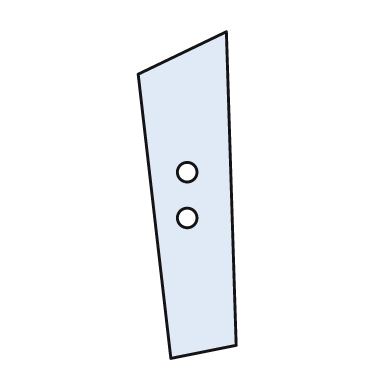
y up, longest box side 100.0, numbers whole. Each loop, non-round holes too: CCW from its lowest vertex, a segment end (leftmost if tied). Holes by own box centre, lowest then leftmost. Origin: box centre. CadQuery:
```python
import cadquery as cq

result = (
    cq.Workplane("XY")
    .moveTo(-5.0, -50.0)
    .lineTo(15.0, -46.0)
    .lineTo(12.0, 50.0)
    .lineTo(-15.0, 37.0)
    .close()
    .moveTo(0.0, -7.0)
    .circle(3.0)
    .moveTo(0.0, 7.0)
    .circle(3.0)
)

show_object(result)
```